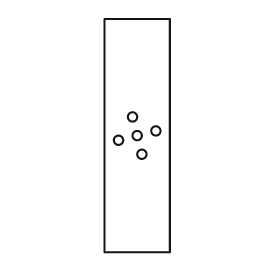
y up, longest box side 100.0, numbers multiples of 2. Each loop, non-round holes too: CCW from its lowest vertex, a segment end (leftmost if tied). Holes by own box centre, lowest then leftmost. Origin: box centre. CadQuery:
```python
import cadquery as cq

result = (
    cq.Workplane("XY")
    .moveTo(-14.0, -50.0)
    .lineTo(14.0, -50.0)
    .lineTo(14.0, 50.0)
    .lineTo(-14.0, 50.0)
    .close()
    .moveTo(2.0, -8.0)
    .circle(2.0)
    .moveTo(-8.0, -2.0)
    .circle(2.0)
    .moveTo(0.0, 0.0)
    .circle(2.0)
    .moveTo(8.0, 2.0)
    .circle(2.0)
    .moveTo(-2.0, 8.0)
    .circle(2.0)
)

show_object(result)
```